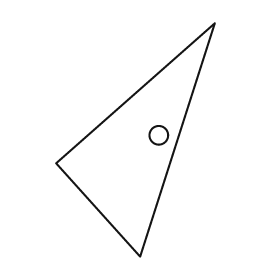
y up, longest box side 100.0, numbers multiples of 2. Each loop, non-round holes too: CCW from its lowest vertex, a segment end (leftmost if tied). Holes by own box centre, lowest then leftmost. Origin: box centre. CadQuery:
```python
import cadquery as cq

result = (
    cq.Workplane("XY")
    .moveTo(2.0, -50.0)
    .lineTo(34.0, 50.0)
    .lineTo(-34.0, -10.0)
    .close()
    .moveTo(10.0, 2.0)
    .circle(4.0)
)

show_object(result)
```